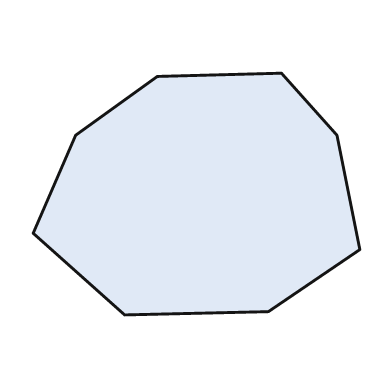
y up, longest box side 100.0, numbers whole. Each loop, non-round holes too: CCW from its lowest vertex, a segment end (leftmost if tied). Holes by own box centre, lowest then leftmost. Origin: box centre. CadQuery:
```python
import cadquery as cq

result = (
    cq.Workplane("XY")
    .moveTo(-22.0, -37.0)
    .lineTo(22.0, -36.0)
    .lineTo(50.0, -17.0)
    .lineTo(43.0, 18.0)
    .lineTo(26.0, 37.0)
    .lineTo(-12.0, 36.0)
    .lineTo(-37.0, 18.0)
    .lineTo(-50.0, -12.0)
    .close()
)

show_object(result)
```